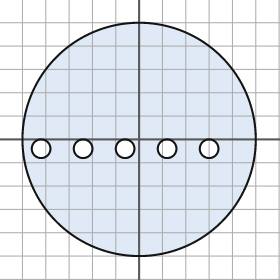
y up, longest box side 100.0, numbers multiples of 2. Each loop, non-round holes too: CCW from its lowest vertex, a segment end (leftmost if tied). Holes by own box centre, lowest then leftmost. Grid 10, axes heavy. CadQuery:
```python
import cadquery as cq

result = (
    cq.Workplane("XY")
    .moveTo(0.0, 0.0)
    .circle(50.0)
    .moveTo(-42.0, -4.0)
    .circle(4.0)
    .moveTo(-24.0, -4.0)
    .circle(4.0)
    .moveTo(-6.0, -4.0)
    .circle(4.0)
    .moveTo(12.0, -4.0)
    .circle(4.0)
    .moveTo(30.0, -4.0)
    .circle(4.0)
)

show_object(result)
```